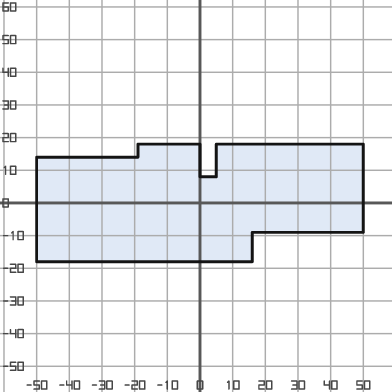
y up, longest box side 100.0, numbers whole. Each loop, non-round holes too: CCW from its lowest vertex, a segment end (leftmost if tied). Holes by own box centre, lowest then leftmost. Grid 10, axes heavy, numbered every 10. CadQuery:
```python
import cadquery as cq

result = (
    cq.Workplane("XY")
    .moveTo(-50.0, -18.0)
    .lineTo(16.0, -18.0)
    .lineTo(16.0, -9.0)
    .lineTo(50.0, -9.0)
    .lineTo(50.0, 18.0)
    .lineTo(5.0, 18.0)
    .lineTo(5.0, 8.0)
    .lineTo(0.0, 8.0)
    .lineTo(0.0, 18.0)
    .lineTo(-19.0, 18.0)
    .lineTo(-19.0, 14.0)
    .lineTo(-50.0, 14.0)
    .close()
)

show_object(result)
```